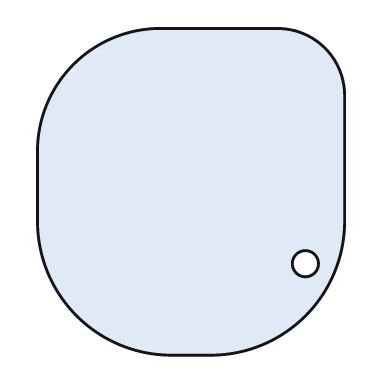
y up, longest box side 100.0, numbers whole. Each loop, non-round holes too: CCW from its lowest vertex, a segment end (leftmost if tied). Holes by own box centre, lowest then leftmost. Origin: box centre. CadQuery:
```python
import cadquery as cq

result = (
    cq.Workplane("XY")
    .moveTo(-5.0, -50.0)
    .lineTo(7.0, -50.0)
    .threePointArc((35.0, -38.0), (47.0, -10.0))
    .lineTo(47.0, 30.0)
    .threePointArc((41.0, 44.0), (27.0, 50.0))
    .lineTo(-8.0, 50.0)
    .threePointArc((-36.0, 39.0), (-47.0, 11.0))
    .lineTo(-47.0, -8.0)
    .threePointArc((-35.0, -38.0), (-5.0, -50.0))
    .close()
    .moveTo(35.0, -22.0)
    .circle(4.0)
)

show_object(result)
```